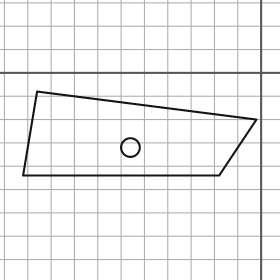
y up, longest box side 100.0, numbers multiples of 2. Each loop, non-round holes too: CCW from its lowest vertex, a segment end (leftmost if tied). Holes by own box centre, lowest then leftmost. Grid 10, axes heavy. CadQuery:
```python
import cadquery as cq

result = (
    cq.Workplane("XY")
    .moveTo(-102.0, -44.0)
    .lineTo(-18.0, -44.0)
    .lineTo(-2.0, -20.0)
    .lineTo(-96.0, -8.0)
    .close()
    .moveTo(-56.0, -32.0)
    .circle(4.0)
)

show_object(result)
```